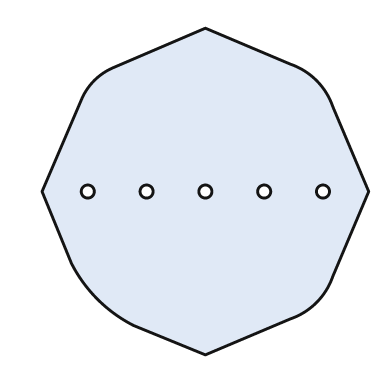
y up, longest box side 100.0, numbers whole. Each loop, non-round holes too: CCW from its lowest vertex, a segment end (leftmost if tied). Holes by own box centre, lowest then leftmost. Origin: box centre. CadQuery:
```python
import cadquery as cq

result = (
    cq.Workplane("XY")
    .moveTo(0.0, -50.0)
    .lineTo(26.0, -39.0)
    .threePointArc((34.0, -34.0), (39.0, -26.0))
    .lineTo(50.0, 0.0)
    .lineTo(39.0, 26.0)
    .threePointArc((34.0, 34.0), (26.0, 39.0))
    .lineTo(0.0, 50.0)
    .lineTo(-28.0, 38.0)
    .threePointArc((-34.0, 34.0), (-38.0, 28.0))
    .lineTo(-50.0, 0.0)
    .lineTo(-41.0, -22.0)
    .threePointArc((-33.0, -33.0), (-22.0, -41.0))
    .close()
    .moveTo(-36.0, 0.0)
    .circle(2.0)
    .moveTo(-18.0, 0.0)
    .circle(2.0)
    .moveTo(0.0, 0.0)
    .circle(2.0)
    .moveTo(18.0, 0.0)
    .circle(2.0)
    .moveTo(36.0, 0.0)
    .circle(2.0)
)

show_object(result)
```